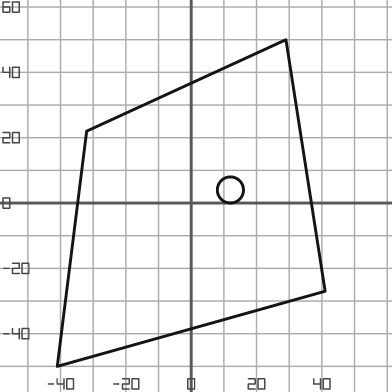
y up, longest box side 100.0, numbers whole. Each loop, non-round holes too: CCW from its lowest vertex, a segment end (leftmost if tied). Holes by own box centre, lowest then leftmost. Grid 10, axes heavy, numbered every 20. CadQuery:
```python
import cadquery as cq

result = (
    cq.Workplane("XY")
    .moveTo(-41.0, -50.0)
    .lineTo(41.0, -27.0)
    .lineTo(29.0, 50.0)
    .lineTo(-32.0, 22.0)
    .close()
    .moveTo(12.0, 4.0)
    .circle(4.0)
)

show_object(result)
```